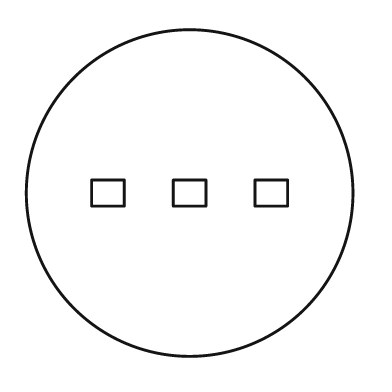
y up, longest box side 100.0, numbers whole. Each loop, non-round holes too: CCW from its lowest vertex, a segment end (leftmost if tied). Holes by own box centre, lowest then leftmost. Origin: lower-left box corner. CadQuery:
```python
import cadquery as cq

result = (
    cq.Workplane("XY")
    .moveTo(50.0, 50.0)
    .circle(50.0)
    .moveTo(20.0, 46.0)
    .lineTo(30.0, 46.0)
    .lineTo(30.0, 54.0)
    .lineTo(20.0, 54.0)
    .close()
    .moveTo(45.0, 46.0)
    .lineTo(55.0, 46.0)
    .lineTo(55.0, 54.0)
    .lineTo(45.0, 54.0)
    .close()
    .moveTo(70.0, 46.0)
    .lineTo(80.0, 46.0)
    .lineTo(80.0, 54.0)
    .lineTo(70.0, 54.0)
    .close()
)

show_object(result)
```